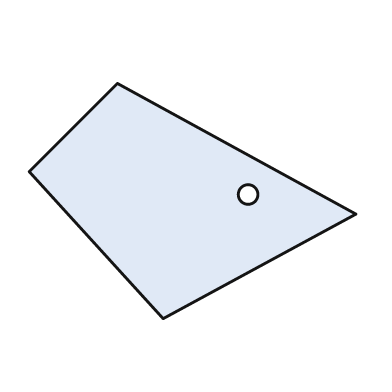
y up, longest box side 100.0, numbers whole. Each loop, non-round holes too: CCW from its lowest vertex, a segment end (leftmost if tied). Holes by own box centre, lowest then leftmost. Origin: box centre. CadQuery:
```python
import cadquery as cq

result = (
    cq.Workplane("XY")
    .moveTo(-9.0, -36.0)
    .lineTo(50.0, -4.0)
    .lineTo(-23.0, 36.0)
    .lineTo(-50.0, 9.0)
    .close()
    .moveTo(17.0, 2.0)
    .circle(3.0)
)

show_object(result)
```